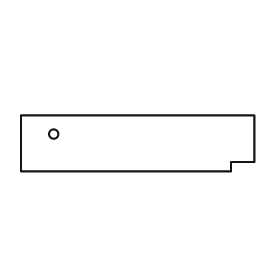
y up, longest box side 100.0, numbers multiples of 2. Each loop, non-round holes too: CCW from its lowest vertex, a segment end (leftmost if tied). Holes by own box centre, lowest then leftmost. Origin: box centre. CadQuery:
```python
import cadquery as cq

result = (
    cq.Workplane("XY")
    .moveTo(-50.0, -12.0)
    .lineTo(40.0, -12.0)
    .lineTo(40.0, -8.0)
    .lineTo(50.0, -8.0)
    .lineTo(50.0, 12.0)
    .lineTo(-50.0, 12.0)
    .close()
    .moveTo(-36.0, 4.0)
    .circle(2.0)
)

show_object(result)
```